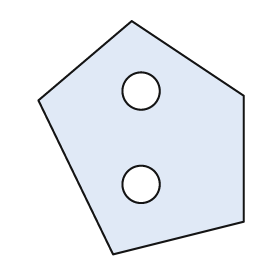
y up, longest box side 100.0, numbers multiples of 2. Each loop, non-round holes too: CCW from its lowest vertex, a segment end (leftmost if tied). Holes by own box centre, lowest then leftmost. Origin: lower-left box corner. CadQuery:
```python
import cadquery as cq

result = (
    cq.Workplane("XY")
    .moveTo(32.0, 0.0)
    .lineTo(88.0, 14.0)
    .lineTo(88.0, 68.0)
    .lineTo(40.0, 100.0)
    .lineTo(0.0, 66.0)
    .close()
    .moveTo(44.0, 30.0)
    .circle(8.0)
    .moveTo(44.0, 70.0)
    .circle(8.0)
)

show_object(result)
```